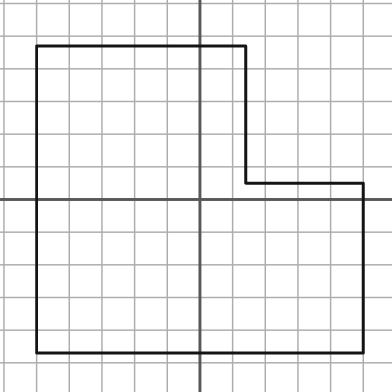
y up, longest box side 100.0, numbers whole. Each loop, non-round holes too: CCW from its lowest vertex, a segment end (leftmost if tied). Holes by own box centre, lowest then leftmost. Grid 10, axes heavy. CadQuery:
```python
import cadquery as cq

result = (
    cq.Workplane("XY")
    .moveTo(-50.0, -47.0)
    .lineTo(50.0, -47.0)
    .lineTo(50.0, 5.0)
    .lineTo(14.0, 5.0)
    .lineTo(14.0, 47.0)
    .lineTo(-50.0, 47.0)
    .close()
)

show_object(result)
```